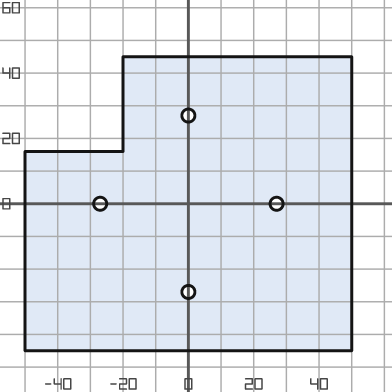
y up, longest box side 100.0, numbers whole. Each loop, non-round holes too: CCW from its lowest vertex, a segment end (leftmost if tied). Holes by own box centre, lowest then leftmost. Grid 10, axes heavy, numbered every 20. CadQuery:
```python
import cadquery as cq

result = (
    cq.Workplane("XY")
    .moveTo(-50.0, -45.0)
    .lineTo(50.0, -45.0)
    .lineTo(50.0, 45.0)
    .lineTo(-20.0, 45.0)
    .lineTo(-20.0, 16.0)
    .lineTo(-50.0, 16.0)
    .close()
    .moveTo(0.0, -27.0)
    .circle(2.0)
    .moveTo(-27.0, 0.0)
    .circle(2.0)
    .moveTo(27.0, 0.0)
    .circle(2.0)
    .moveTo(0.0, 27.0)
    .circle(2.0)
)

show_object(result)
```